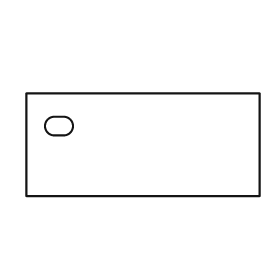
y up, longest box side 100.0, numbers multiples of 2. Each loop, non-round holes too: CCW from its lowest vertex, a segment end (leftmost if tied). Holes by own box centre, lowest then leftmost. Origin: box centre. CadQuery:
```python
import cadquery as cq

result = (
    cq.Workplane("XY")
    .moveTo(-50.0, -22.0)
    .lineTo(50.0, -22.0)
    .lineTo(50.0, 22.0)
    .lineTo(-50.0, 22.0)
    .close()
    .moveTo(-38.0, 4.0)
    .lineTo(-34.0, 4.0)
    .threePointArc((-30.0, 8.0), (-34.0, 12.0))
    .lineTo(-38.0, 12.0)
    .threePointArc((-42.0, 8.0), (-38.0, 4.0))
    .close()
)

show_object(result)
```